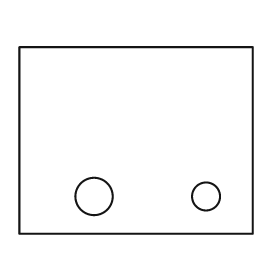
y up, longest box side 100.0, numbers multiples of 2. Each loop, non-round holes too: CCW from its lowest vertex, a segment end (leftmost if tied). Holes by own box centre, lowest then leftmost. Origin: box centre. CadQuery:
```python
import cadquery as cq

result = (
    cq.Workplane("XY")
    .moveTo(-50.0, -40.0)
    .lineTo(50.0, -40.0)
    .lineTo(50.0, 40.0)
    .lineTo(-50.0, 40.0)
    .close()
    .moveTo(-18.0, -24.0)
    .circle(8.0)
    .moveTo(30.0, -24.0)
    .circle(6.0)
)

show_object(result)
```